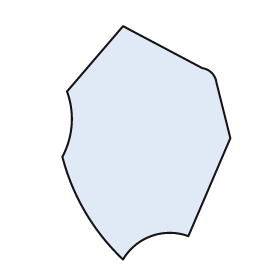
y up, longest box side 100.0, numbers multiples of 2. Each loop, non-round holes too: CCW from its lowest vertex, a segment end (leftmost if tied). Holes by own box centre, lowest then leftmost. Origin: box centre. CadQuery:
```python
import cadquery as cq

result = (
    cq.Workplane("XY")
    .moveTo(-10.0, -50.0)
    .threePointArc((2.0, -40.0), (18.0, -40.0))
    .lineTo(36.0, 2.0)
    .lineTo(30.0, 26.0)
    .threePointArc((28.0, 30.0), (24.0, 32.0))
    .lineTo(-10.0, 50.0)
    .lineTo(-34.0, 22.0)
    .threePointArc((-32.0, 8.0), (-36.0, -6.0))
    .threePointArc((-26.0, -30.0), (-10.0, -50.0))
    .close()
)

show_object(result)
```